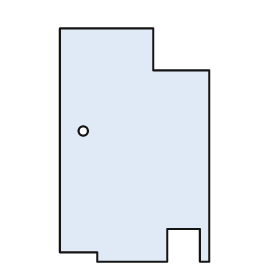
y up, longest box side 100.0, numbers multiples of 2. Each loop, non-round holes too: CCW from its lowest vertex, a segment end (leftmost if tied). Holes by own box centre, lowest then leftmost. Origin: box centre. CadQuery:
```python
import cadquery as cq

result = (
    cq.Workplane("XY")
    .moveTo(-16.0, -50.0)
    .lineTo(14.0, -50.0)
    .lineTo(14.0, -36.0)
    .lineTo(28.0, -36.0)
    .lineTo(28.0, -50.0)
    .lineTo(32.0, -50.0)
    .lineTo(32.0, 32.0)
    .lineTo(8.0, 32.0)
    .lineTo(8.0, 50.0)
    .lineTo(-32.0, 50.0)
    .lineTo(-32.0, -46.0)
    .lineTo(-16.0, -46.0)
    .close()
    .moveTo(-22.0, 6.0)
    .circle(2.0)
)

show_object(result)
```